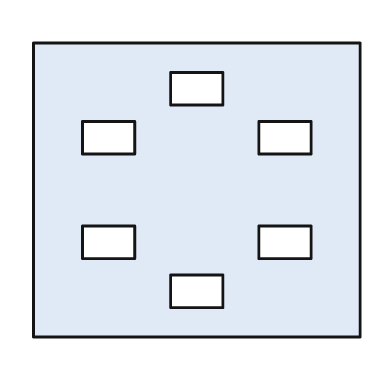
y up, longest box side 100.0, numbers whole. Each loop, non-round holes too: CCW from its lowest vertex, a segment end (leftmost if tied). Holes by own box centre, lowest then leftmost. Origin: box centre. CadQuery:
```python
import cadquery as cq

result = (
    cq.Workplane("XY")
    .moveTo(-50.0, -45.0)
    .lineTo(50.0, -45.0)
    .lineTo(50.0, 45.0)
    .lineTo(-50.0, 45.0)
    .close()
    .moveTo(-8.0, -36.0)
    .lineTo(8.0, -36.0)
    .lineTo(8.0, -26.0)
    .lineTo(-8.0, -26.0)
    .close()
    .moveTo(-35.0, -21.0)
    .lineTo(-19.0, -21.0)
    .lineTo(-19.0, -11.0)
    .lineTo(-35.0, -11.0)
    .close()
    .moveTo(19.0, -21.0)
    .lineTo(35.0, -21.0)
    .lineTo(35.0, -11.0)
    .lineTo(19.0, -11.0)
    .close()
    .moveTo(-35.0, 11.0)
    .lineTo(-19.0, 11.0)
    .lineTo(-19.0, 21.0)
    .lineTo(-35.0, 21.0)
    .close()
    .moveTo(19.0, 11.0)
    .lineTo(35.0, 11.0)
    .lineTo(35.0, 21.0)
    .lineTo(19.0, 21.0)
    .close()
    .moveTo(-8.0, 26.0)
    .lineTo(8.0, 26.0)
    .lineTo(8.0, 36.0)
    .lineTo(-8.0, 36.0)
    .close()
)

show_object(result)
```